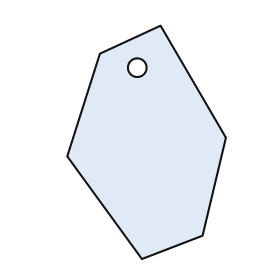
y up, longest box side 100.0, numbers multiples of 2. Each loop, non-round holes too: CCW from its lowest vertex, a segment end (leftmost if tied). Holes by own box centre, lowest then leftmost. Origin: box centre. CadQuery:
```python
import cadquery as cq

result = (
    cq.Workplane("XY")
    .moveTo(-2.0, -50.0)
    .lineTo(24.0, -40.0)
    .lineTo(34.0, 2.0)
    .lineTo(6.0, 50.0)
    .lineTo(-20.0, 38.0)
    .lineTo(-34.0, -6.0)
    .close()
    .moveTo(-4.0, 32.0)
    .circle(4.0)
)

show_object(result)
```